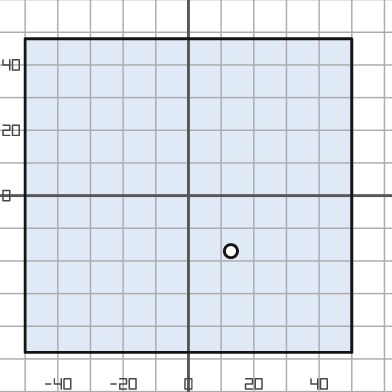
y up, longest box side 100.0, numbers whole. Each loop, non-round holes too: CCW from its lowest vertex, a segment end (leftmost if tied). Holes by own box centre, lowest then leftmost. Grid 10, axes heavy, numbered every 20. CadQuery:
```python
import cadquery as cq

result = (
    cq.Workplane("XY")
    .moveTo(-50.0, -48.0)
    .lineTo(50.0, -48.0)
    .lineTo(50.0, 48.0)
    .lineTo(-50.0, 48.0)
    .close()
    .moveTo(13.0, -17.0)
    .circle(2.0)
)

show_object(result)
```